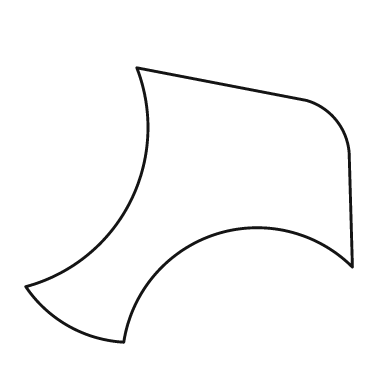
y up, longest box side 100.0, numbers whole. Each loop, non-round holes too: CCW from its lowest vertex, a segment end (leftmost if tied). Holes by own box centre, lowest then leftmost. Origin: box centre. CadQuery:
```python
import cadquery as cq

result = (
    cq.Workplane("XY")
    .moveTo(-20.0, -42.0)
    .threePointArc((8.0, -9.0), (50.0, -19.0))
    .lineTo(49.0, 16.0)
    .threePointArc((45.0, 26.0), (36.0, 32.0))
    .lineTo(-16.0, 42.0)
    .threePointArc((-18.0, 1.0), (-50.0, -25.0))
    .threePointArc((-37.0, -37.0), (-20.0, -42.0))
    .close()
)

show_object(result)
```